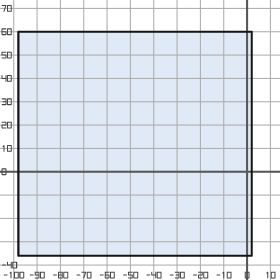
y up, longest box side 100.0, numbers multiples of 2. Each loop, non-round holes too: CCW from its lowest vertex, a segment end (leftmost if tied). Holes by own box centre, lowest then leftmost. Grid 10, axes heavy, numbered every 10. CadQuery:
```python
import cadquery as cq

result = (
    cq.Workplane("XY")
    .moveTo(-98.0, -36.0)
    .lineTo(2.0, -36.0)
    .lineTo(2.0, 60.0)
    .lineTo(-98.0, 60.0)
    .close()
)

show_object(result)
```